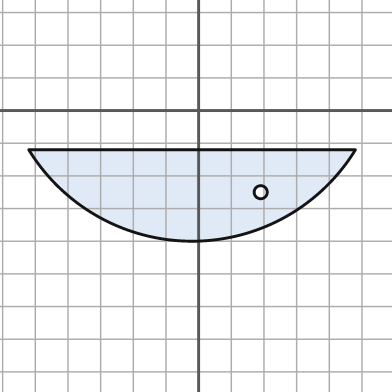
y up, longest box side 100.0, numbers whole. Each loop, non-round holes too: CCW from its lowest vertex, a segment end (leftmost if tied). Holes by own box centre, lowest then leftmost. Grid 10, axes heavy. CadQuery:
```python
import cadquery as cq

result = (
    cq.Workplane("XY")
    .moveTo(-52.0, -12.0)
    .threePointArc((-2.0, -40.0), (48.0, -12.0))
    .close()
    .moveTo(19.0, -25.0)
    .circle(2.0)
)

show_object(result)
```